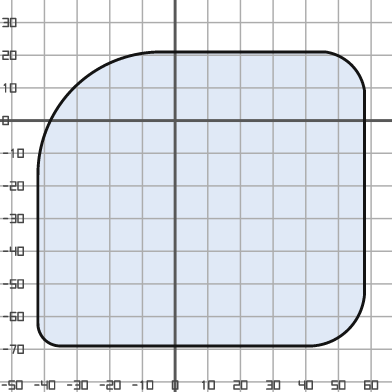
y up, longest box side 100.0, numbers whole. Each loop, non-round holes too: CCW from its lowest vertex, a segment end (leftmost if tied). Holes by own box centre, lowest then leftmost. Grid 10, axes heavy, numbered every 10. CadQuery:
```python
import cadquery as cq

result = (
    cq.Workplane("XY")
    .moveTo(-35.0, -69.0)
    .lineTo(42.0, -69.0)
    .threePointArc((53.0, -64.0), (58.0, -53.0))
    .lineTo(58.0, 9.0)
    .threePointArc((54.0, 17.0), (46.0, 21.0))
    .lineTo(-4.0, 21.0)
    .threePointArc((-31.0, 10.0), (-42.0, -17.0))
    .lineTo(-42.0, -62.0)
    .threePointArc((-40.0, -67.0), (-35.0, -69.0))
    .close()
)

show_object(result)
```